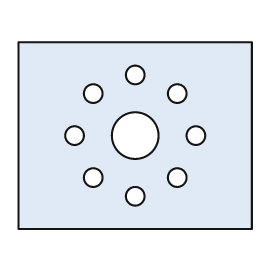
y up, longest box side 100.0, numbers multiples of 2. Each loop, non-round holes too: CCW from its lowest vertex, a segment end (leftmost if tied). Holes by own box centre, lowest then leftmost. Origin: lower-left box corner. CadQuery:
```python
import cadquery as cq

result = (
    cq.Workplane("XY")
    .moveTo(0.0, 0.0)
    .lineTo(100.0, 0.0)
    .lineTo(100.0, 80.0)
    .lineTo(0.0, 80.0)
    .close()
    .moveTo(50.0, 14.0)
    .circle(4.0)
    .moveTo(32.0, 22.0)
    .circle(4.0)
    .moveTo(68.0, 22.0)
    .circle(4.0)
    .moveTo(24.0, 40.0)
    .circle(4.0)
    .moveTo(50.0, 40.0)
    .circle(10.0)
    .moveTo(76.0, 40.0)
    .circle(4.0)
    .moveTo(32.0, 58.0)
    .circle(4.0)
    .moveTo(68.0, 58.0)
    .circle(4.0)
    .moveTo(50.0, 66.0)
    .circle(4.0)
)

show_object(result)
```